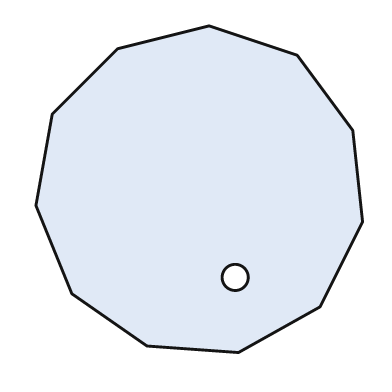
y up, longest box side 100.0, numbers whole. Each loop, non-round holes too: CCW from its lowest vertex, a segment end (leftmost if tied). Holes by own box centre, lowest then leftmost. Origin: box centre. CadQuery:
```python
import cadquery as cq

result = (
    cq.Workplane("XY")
    .moveTo(12.0, -50.0)
    .lineTo(37.0, -36.0)
    .lineTo(50.0, -10.0)
    .lineTo(47.0, 18.0)
    .lineTo(30.0, 41.0)
    .lineTo(3.0, 50.0)
    .lineTo(-25.0, 43.0)
    .lineTo(-45.0, 23.0)
    .lineTo(-50.0, -5.0)
    .lineTo(-39.0, -32.0)
    .lineTo(-16.0, -48.0)
    .close()
    .moveTo(11.0, -27.0)
    .circle(4.0)
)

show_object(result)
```